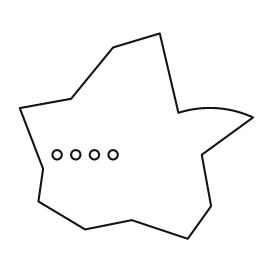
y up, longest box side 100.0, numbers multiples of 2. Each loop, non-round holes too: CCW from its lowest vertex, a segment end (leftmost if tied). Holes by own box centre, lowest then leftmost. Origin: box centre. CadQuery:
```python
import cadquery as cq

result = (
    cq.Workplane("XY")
    .moveTo(22.0, -44.0)
    .lineTo(32.0, -30.0)
    .lineTo(28.0, -8.0)
    .lineTo(50.0, 8.0)
    .threePointArc((34.0, 12.0), (18.0, 10.0))
    .lineTo(10.0, 44.0)
    .lineTo(-10.0, 38.0)
    .lineTo(-28.0, 16.0)
    .lineTo(-50.0, 12.0)
    .lineTo(-40.0, -14.0)
    .lineTo(-42.0, -28.0)
    .lineTo(-22.0, -40.0)
    .lineTo(-2.0, -36.0)
    .close()
    .moveTo(-34.0, -8.0)
    .circle(2.0)
    .moveTo(-26.0, -8.0)
    .circle(2.0)
    .moveTo(-18.0, -8.0)
    .circle(2.0)
    .moveTo(-10.0, -8.0)
    .circle(2.0)
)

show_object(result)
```